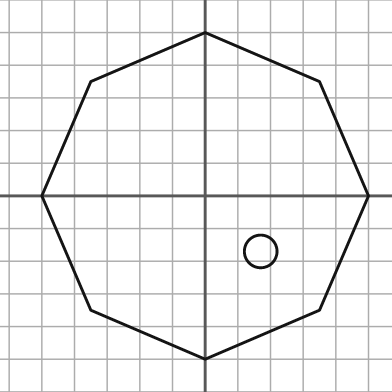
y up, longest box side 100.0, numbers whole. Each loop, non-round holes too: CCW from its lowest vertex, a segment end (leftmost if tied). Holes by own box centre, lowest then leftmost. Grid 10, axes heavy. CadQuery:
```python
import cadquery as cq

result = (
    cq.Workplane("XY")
    .moveTo(0.0, -50.0)
    .lineTo(35.0, -35.0)
    .lineTo(50.0, 0.0)
    .lineTo(35.0, 35.0)
    .lineTo(0.0, 50.0)
    .lineTo(-35.0, 35.0)
    .lineTo(-50.0, 0.0)
    .lineTo(-35.0, -35.0)
    .close()
    .moveTo(17.0, -17.0)
    .circle(5.0)
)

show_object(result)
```